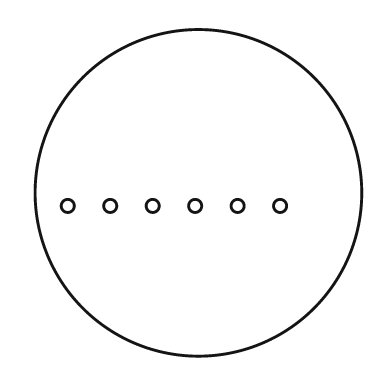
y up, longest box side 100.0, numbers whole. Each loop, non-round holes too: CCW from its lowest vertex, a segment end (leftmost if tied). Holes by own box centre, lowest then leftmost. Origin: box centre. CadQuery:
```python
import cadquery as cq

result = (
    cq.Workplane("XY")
    .moveTo(0.0, 0.0)
    .circle(50.0)
    .moveTo(-40.0, -4.0)
    .circle(2.0)
    .moveTo(-27.0, -4.0)
    .circle(2.0)
    .moveTo(-14.0, -4.0)
    .circle(2.0)
    .moveTo(-1.0, -4.0)
    .circle(2.0)
    .moveTo(12.0, -4.0)
    .circle(2.0)
    .moveTo(25.0, -4.0)
    .circle(2.0)
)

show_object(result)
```